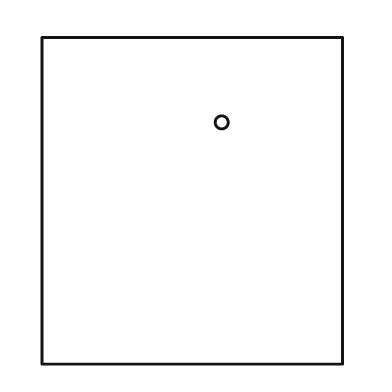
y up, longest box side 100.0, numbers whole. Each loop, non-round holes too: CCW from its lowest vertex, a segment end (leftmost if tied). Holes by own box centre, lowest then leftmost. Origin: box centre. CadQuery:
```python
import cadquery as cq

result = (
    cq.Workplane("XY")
    .moveTo(-46.0, -50.0)
    .lineTo(46.0, -50.0)
    .lineTo(46.0, 50.0)
    .lineTo(-46.0, 50.0)
    .close()
    .moveTo(9.0, 24.0)
    .circle(2.0)
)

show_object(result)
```